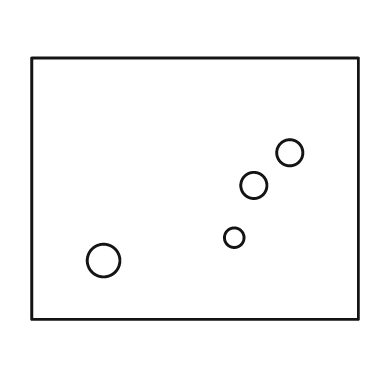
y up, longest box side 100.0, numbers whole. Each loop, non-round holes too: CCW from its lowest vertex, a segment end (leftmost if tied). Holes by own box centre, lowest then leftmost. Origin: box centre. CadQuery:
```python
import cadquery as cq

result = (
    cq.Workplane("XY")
    .moveTo(-50.0, -40.0)
    .lineTo(50.0, -40.0)
    .lineTo(50.0, 40.0)
    .lineTo(-50.0, 40.0)
    .close()
    .moveTo(-28.0, -22.0)
    .circle(5.0)
    .moveTo(12.0, -15.0)
    .circle(3.0)
    .moveTo(18.0, 1.0)
    .circle(4.0)
    .moveTo(29.0, 11.0)
    .circle(4.0)
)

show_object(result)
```